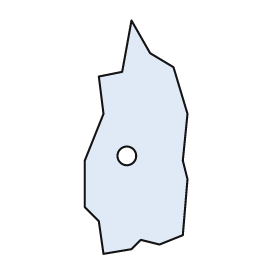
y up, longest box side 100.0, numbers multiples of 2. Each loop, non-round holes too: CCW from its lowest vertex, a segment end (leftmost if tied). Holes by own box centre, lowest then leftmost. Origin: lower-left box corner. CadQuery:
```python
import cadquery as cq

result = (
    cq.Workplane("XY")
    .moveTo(8.0, 0.0)
    .lineTo(20.0, 2.0)
    .lineTo(24.0, 6.0)
    .lineTo(32.0, 4.0)
    .lineTo(42.0, 8.0)
    .lineTo(44.0, 32.0)
    .lineTo(42.0, 40.0)
    .lineTo(44.0, 60.0)
    .lineTo(38.0, 80.0)
    .lineTo(28.0, 86.0)
    .lineTo(20.0, 100.0)
    .lineTo(16.0, 78.0)
    .lineTo(6.0, 76.0)
    .lineTo(8.0, 60.0)
    .lineTo(0.0, 40.0)
    .lineTo(0.0, 20.0)
    .lineTo(6.0, 14.0)
    .close()
    .moveTo(18.0, 42.0)
    .circle(4.0)
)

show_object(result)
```